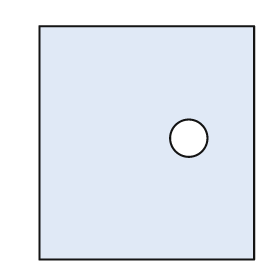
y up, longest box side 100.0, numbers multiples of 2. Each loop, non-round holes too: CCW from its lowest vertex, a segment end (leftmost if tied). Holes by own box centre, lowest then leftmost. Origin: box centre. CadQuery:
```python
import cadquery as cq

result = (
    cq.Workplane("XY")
    .moveTo(-46.0, -50.0)
    .lineTo(46.0, -50.0)
    .lineTo(46.0, 50.0)
    .lineTo(-46.0, 50.0)
    .close()
    .moveTo(18.0, 2.0)
    .circle(8.0)
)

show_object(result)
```